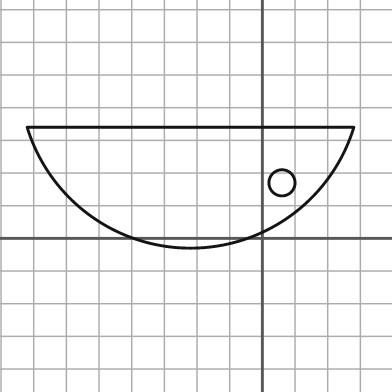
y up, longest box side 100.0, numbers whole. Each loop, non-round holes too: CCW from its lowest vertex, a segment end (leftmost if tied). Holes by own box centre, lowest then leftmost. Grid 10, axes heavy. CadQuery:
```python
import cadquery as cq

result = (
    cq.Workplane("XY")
    .moveTo(-72.0, 34.0)
    .threePointArc((-22.0, -3.0), (28.0, 34.0))
    .close()
    .moveTo(6.0, 17.0)
    .circle(4.0)
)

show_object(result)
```